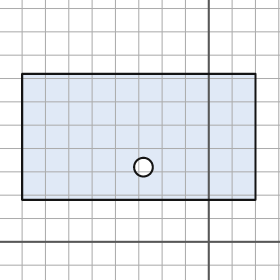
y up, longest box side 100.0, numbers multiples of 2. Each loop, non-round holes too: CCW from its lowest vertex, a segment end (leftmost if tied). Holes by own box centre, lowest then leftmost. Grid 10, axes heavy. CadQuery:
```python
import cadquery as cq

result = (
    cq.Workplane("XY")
    .moveTo(-80.0, 18.0)
    .lineTo(20.0, 18.0)
    .lineTo(20.0, 72.0)
    .lineTo(-80.0, 72.0)
    .close()
    .moveTo(-28.0, 32.0)
    .circle(4.0)
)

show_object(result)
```